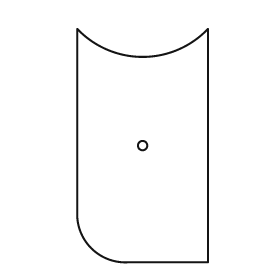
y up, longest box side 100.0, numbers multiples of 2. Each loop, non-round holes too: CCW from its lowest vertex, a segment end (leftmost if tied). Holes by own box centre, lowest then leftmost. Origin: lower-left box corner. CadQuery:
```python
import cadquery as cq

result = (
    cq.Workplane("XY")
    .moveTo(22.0, 0.0)
    .lineTo(56.0, 0.0)
    .lineTo(56.0, 100.0)
    .threePointArc((28.0, 88.0), (0.0, 100.0))
    .lineTo(0.0, 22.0)
    .threePointArc((6.0, 6.0), (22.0, 0.0))
    .close()
    .moveTo(28.0, 50.0)
    .circle(2.0)
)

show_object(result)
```